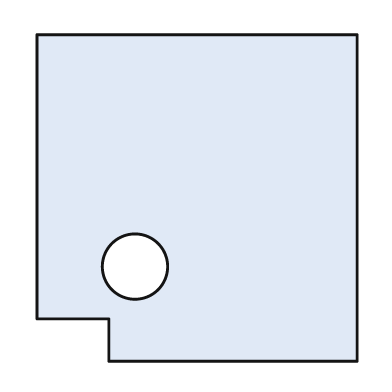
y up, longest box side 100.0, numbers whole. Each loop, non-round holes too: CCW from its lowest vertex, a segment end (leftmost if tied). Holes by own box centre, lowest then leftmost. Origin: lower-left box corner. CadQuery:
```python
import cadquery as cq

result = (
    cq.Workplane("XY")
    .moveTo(22.0, 0.0)
    .lineTo(98.0, 0.0)
    .lineTo(98.0, 100.0)
    .lineTo(0.0, 100.0)
    .lineTo(0.0, 13.0)
    .lineTo(22.0, 13.0)
    .close()
    .moveTo(30.0, 29.0)
    .circle(10.0)
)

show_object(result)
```